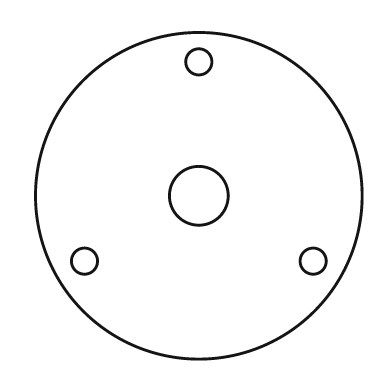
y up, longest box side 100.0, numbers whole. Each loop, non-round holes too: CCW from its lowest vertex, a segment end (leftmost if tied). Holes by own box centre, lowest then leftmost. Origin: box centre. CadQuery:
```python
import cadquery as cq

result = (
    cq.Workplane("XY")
    .moveTo(0.0, 0.0)
    .circle(50.0)
    .moveTo(-35.0, -20.0)
    .circle(4.0)
    .moveTo(35.0, -20.0)
    .circle(4.0)
    .moveTo(0.0, 0.0)
    .circle(9.0)
    .moveTo(0.0, 41.0)
    .circle(4.0)
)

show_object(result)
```